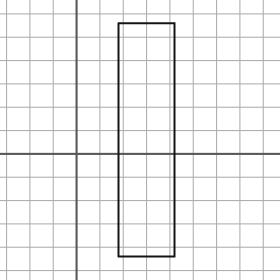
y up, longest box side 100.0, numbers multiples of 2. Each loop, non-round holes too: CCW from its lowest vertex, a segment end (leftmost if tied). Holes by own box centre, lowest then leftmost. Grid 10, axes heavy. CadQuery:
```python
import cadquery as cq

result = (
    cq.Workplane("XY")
    .moveTo(18.0, -44.0)
    .lineTo(42.0, -44.0)
    .lineTo(42.0, 56.0)
    .lineTo(18.0, 56.0)
    .close()
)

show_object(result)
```